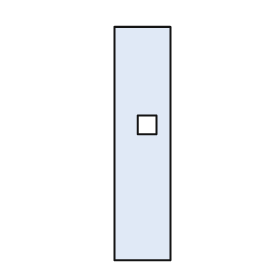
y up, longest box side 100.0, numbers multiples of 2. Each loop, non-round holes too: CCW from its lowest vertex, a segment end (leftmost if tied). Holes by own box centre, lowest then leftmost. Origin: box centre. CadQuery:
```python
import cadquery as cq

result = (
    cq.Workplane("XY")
    .moveTo(-12.0, -50.0)
    .lineTo(12.0, -50.0)
    .lineTo(12.0, 50.0)
    .lineTo(-12.0, 50.0)
    .close()
    .moveTo(-2.0, 4.0)
    .lineTo(6.0, 4.0)
    .lineTo(6.0, 12.0)
    .lineTo(-2.0, 12.0)
    .close()
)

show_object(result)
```